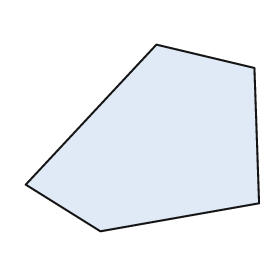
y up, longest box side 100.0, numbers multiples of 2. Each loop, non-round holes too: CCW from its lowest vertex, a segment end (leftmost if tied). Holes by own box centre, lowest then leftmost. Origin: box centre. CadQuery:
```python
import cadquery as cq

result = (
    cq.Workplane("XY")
    .moveTo(-18.0, -40.0)
    .lineTo(50.0, -28.0)
    .lineTo(48.0, 30.0)
    .lineTo(6.0, 40.0)
    .lineTo(-50.0, -20.0)
    .close()
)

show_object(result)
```